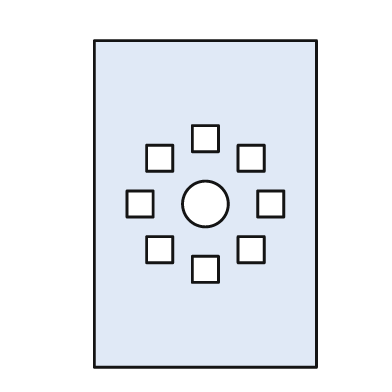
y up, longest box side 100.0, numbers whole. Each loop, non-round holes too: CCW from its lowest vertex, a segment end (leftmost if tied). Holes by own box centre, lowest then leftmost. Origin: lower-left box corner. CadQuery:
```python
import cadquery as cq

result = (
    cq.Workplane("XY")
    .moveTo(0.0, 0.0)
    .lineTo(68.0, 0.0)
    .lineTo(68.0, 100.0)
    .lineTo(0.0, 100.0)
    .close()
    .moveTo(30.0, 26.0)
    .lineTo(38.0, 26.0)
    .lineTo(38.0, 34.0)
    .lineTo(30.0, 34.0)
    .close()
    .moveTo(16.0, 32.0)
    .lineTo(24.0, 32.0)
    .lineTo(24.0, 40.0)
    .lineTo(16.0, 40.0)
    .close()
    .moveTo(44.0, 32.0)
    .lineTo(52.0, 32.0)
    .lineTo(52.0, 40.0)
    .lineTo(44.0, 40.0)
    .close()
    .moveTo(10.0, 46.0)
    .lineTo(18.0, 46.0)
    .lineTo(18.0, 54.0)
    .lineTo(10.0, 54.0)
    .close()
    .moveTo(34.0, 50.0)
    .circle(7.0)
    .moveTo(50.0, 46.0)
    .lineTo(58.0, 46.0)
    .lineTo(58.0, 54.0)
    .lineTo(50.0, 54.0)
    .close()
    .moveTo(16.0, 60.0)
    .lineTo(24.0, 60.0)
    .lineTo(24.0, 68.0)
    .lineTo(16.0, 68.0)
    .close()
    .moveTo(44.0, 60.0)
    .lineTo(52.0, 60.0)
    .lineTo(52.0, 68.0)
    .lineTo(44.0, 68.0)
    .close()
    .moveTo(30.0, 66.0)
    .lineTo(38.0, 66.0)
    .lineTo(38.0, 74.0)
    .lineTo(30.0, 74.0)
    .close()
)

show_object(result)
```